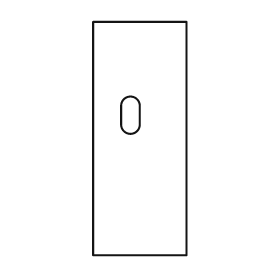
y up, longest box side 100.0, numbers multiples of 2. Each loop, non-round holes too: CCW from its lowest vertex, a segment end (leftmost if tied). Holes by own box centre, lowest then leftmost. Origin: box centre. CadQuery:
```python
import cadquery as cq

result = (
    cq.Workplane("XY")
    .moveTo(-20.0, -50.0)
    .lineTo(20.0, -50.0)
    .lineTo(20.0, 50.0)
    .lineTo(-20.0, 50.0)
    .close()
    .moveTo(-8.0, 6.0)
    .threePointArc((-4.0, 2.0), (0.0, 6.0))
    .lineTo(0.0, 14.0)
    .threePointArc((-4.0, 18.0), (-8.0, 14.0))
    .close()
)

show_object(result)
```